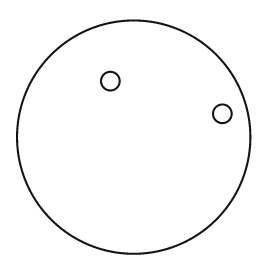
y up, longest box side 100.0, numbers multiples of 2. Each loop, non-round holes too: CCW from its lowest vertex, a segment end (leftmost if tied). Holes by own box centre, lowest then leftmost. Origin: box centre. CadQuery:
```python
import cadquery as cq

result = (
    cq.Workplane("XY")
    .moveTo(0.0, 0.0)
    .circle(50.0)
    .moveTo(38.0, 10.0)
    .circle(4.0)
    .moveTo(-10.0, 24.0)
    .circle(4.0)
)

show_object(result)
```